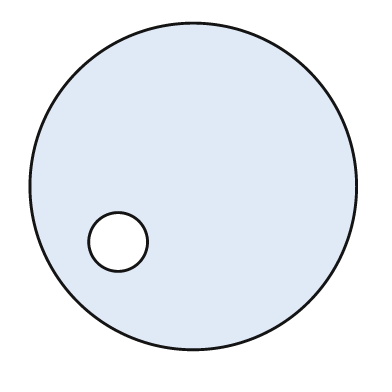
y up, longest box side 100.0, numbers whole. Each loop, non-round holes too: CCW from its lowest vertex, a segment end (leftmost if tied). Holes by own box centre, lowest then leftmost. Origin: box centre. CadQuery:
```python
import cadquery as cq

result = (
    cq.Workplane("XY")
    .moveTo(0.0, 0.0)
    .circle(50.0)
    .moveTo(-23.0, -17.0)
    .circle(9.0)
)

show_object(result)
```